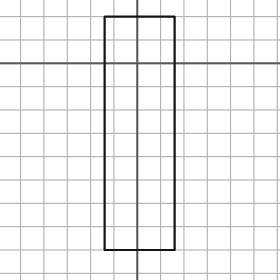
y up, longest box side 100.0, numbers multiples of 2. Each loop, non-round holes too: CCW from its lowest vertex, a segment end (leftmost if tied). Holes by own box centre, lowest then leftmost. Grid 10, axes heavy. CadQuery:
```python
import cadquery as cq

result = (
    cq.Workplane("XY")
    .moveTo(-14.0, -80.0)
    .lineTo(16.0, -80.0)
    .lineTo(16.0, 20.0)
    .lineTo(-14.0, 20.0)
    .close()
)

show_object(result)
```